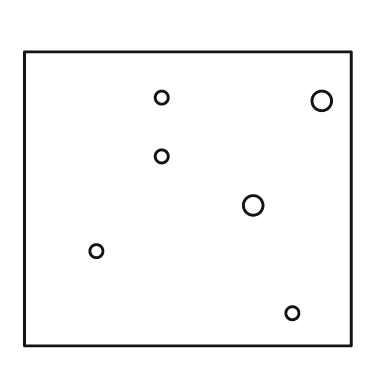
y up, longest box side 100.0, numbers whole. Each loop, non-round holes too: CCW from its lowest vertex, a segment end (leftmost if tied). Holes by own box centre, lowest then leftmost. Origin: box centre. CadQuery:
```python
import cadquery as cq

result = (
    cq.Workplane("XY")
    .moveTo(-50.0, -45.0)
    .lineTo(50.0, -45.0)
    .lineTo(50.0, 45.0)
    .lineTo(-50.0, 45.0)
    .close()
    .moveTo(32.0, -35.0)
    .circle(2.0)
    .moveTo(-28.0, -16.0)
    .circle(2.0)
    .moveTo(20.0, -2.0)
    .circle(3.0)
    .moveTo(-8.0, 13.0)
    .circle(2.0)
    .moveTo(41.0, 30.0)
    .circle(3.0)
    .moveTo(-8.0, 31.0)
    .circle(2.0)
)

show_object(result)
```